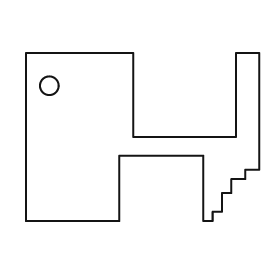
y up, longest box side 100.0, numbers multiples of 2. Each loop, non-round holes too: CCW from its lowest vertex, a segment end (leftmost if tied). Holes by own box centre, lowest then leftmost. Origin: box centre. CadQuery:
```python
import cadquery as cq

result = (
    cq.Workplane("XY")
    .moveTo(-50.0, -36.0)
    .lineTo(-10.0, -36.0)
    .lineTo(-10.0, -8.0)
    .lineTo(26.0, -8.0)
    .lineTo(26.0, -36.0)
    .lineTo(30.0, -36.0)
    .lineTo(30.0, -32.0)
    .lineTo(34.0, -32.0)
    .lineTo(34.0, -24.0)
    .lineTo(38.0, -24.0)
    .lineTo(38.0, -18.0)
    .lineTo(44.0, -18.0)
    .lineTo(44.0, -14.0)
    .lineTo(50.0, -14.0)
    .lineTo(50.0, 36.0)
    .lineTo(40.0, 36.0)
    .lineTo(40.0, 0.0)
    .lineTo(-4.0, 0.0)
    .lineTo(-4.0, 36.0)
    .lineTo(-50.0, 36.0)
    .close()
    .moveTo(-40.0, 22.0)
    .circle(4.0)
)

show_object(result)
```